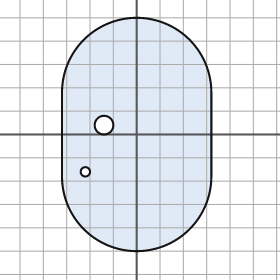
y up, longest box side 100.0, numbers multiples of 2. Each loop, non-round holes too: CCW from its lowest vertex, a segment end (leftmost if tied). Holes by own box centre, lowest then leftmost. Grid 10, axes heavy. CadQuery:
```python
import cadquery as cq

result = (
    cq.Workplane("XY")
    .moveTo(-32.0, -18.0)
    .threePointArc((0.0, -50.0), (32.0, -18.0))
    .lineTo(32.0, 18.0)
    .threePointArc((0.0, 50.0), (-32.0, 18.0))
    .close()
    .moveTo(-22.0, -16.0)
    .circle(2.0)
    .moveTo(-14.0, 4.0)
    .circle(4.0)
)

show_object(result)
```